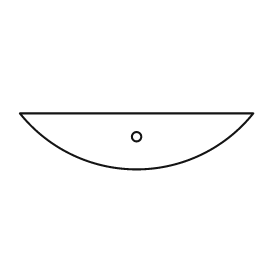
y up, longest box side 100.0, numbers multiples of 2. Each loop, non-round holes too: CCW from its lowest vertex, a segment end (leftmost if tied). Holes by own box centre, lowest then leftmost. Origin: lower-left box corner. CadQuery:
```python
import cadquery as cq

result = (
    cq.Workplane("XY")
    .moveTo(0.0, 24.0)
    .threePointArc((50.0, 0.0), (100.0, 24.0))
    .close()
    .moveTo(50.0, 14.0)
    .circle(2.0)
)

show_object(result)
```